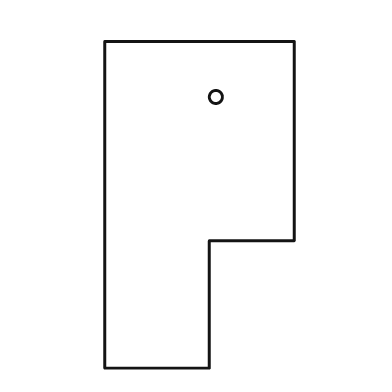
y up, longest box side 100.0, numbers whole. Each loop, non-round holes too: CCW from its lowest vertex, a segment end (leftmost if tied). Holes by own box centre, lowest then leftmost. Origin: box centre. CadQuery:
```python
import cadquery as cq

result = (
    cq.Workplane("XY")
    .moveTo(-29.0, -50.0)
    .lineTo(3.0, -50.0)
    .lineTo(3.0, -11.0)
    .lineTo(29.0, -11.0)
    .lineTo(29.0, 50.0)
    .lineTo(-29.0, 50.0)
    .close()
    .moveTo(5.0, 33.0)
    .circle(2.0)
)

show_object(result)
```